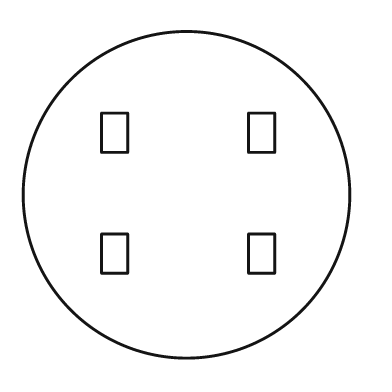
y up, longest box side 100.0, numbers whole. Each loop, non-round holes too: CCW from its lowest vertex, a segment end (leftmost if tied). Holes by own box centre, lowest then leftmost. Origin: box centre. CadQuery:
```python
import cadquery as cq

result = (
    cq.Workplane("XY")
    .moveTo(0.0, 0.0)
    .circle(50.0)
    .moveTo(-26.0, -24.0)
    .lineTo(-18.0, -24.0)
    .lineTo(-18.0, -12.0)
    .lineTo(-26.0, -12.0)
    .close()
    .moveTo(19.0, -24.0)
    .lineTo(27.0, -24.0)
    .lineTo(27.0, -12.0)
    .lineTo(19.0, -12.0)
    .close()
    .moveTo(-26.0, 13.0)
    .lineTo(-18.0, 13.0)
    .lineTo(-18.0, 25.0)
    .lineTo(-26.0, 25.0)
    .close()
    .moveTo(19.0, 13.0)
    .lineTo(27.0, 13.0)
    .lineTo(27.0, 25.0)
    .lineTo(19.0, 25.0)
    .close()
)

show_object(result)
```